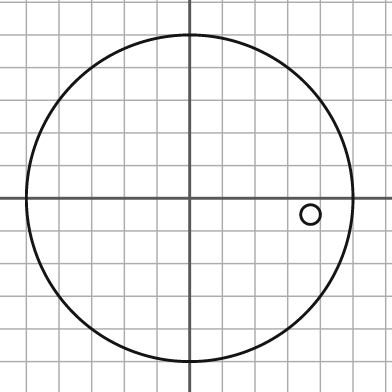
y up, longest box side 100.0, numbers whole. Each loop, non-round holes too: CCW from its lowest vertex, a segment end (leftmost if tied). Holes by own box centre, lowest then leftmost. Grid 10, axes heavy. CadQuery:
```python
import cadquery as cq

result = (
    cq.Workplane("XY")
    .moveTo(0.0, 0.0)
    .circle(50.0)
    .moveTo(37.0, -5.0)
    .circle(3.0)
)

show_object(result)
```